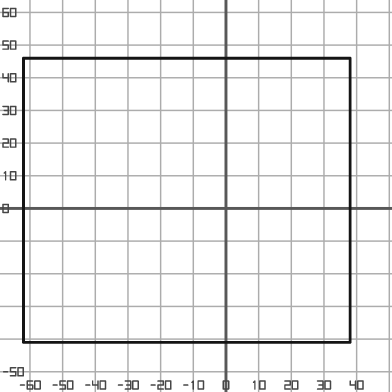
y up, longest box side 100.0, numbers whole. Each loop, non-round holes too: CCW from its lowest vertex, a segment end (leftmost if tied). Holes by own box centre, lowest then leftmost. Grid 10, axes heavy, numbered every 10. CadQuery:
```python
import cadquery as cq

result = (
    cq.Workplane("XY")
    .moveTo(-62.0, -41.0)
    .lineTo(38.0, -41.0)
    .lineTo(38.0, 46.0)
    .lineTo(-62.0, 46.0)
    .close()
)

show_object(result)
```